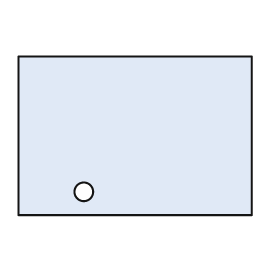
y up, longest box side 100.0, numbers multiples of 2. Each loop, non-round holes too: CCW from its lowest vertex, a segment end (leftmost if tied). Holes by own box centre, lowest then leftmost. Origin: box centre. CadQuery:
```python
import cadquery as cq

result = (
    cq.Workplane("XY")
    .moveTo(-50.0, -34.0)
    .lineTo(50.0, -34.0)
    .lineTo(50.0, 34.0)
    .lineTo(-50.0, 34.0)
    .close()
    .moveTo(-22.0, -24.0)
    .circle(4.0)
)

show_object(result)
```